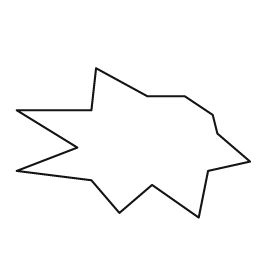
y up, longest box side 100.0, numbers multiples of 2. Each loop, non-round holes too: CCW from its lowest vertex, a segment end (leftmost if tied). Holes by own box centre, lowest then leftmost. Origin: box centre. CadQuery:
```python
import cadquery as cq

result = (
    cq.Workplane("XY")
    .moveTo(28.0, -32.0)
    .lineTo(32.0, -12.0)
    .lineTo(50.0, -8.0)
    .lineTo(36.0, 4.0)
    .lineTo(34.0, 12.0)
    .lineTo(22.0, 20.0)
    .lineTo(6.0, 20.0)
    .lineTo(-16.0, 32.0)
    .lineTo(-18.0, 14.0)
    .lineTo(-50.0, 14.0)
    .lineTo(-24.0, -2.0)
    .lineTo(-50.0, -12.0)
    .lineTo(-18.0, -16.0)
    .lineTo(-6.0, -30.0)
    .lineTo(8.0, -18.0)
    .close()
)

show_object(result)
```